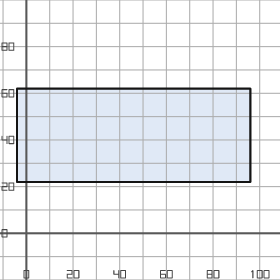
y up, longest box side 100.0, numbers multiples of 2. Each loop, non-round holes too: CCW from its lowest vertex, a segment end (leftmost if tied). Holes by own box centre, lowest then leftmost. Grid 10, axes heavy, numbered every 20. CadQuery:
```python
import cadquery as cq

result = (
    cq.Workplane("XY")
    .moveTo(-4.0, 22.0)
    .lineTo(96.0, 22.0)
    .lineTo(96.0, 62.0)
    .lineTo(-4.0, 62.0)
    .close()
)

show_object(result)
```